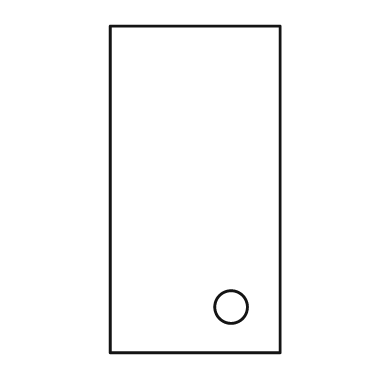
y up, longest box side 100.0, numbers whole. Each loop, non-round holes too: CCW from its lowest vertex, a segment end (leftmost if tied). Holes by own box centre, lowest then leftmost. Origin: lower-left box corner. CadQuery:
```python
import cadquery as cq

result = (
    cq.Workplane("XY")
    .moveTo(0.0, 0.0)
    .lineTo(52.0, 0.0)
    .lineTo(52.0, 100.0)
    .lineTo(0.0, 100.0)
    .close()
    .moveTo(37.0, 14.0)
    .circle(5.0)
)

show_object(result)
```